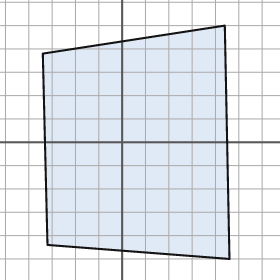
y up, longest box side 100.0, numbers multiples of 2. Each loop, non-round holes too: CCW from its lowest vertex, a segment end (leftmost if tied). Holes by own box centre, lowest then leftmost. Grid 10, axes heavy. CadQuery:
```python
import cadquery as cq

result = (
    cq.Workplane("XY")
    .moveTo(46.0, -50.0)
    .lineTo(44.0, 50.0)
    .lineTo(-34.0, 38.0)
    .lineTo(-32.0, -44.0)
    .close()
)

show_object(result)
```